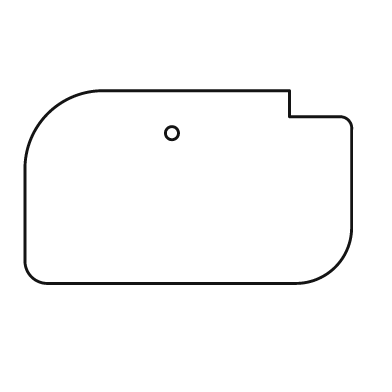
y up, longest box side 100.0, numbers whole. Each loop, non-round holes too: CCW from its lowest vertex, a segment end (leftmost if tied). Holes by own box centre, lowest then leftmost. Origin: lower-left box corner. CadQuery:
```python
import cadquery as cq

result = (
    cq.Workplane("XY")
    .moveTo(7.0, 0.0)
    .lineTo(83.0, 0.0)
    .threePointArc((95.0, 5.0), (100.0, 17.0))
    .lineTo(100.0, 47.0)
    .threePointArc((99.0, 50.0), (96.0, 51.0))
    .lineTo(81.0, 51.0)
    .lineTo(81.0, 59.0)
    .lineTo(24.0, 59.0)
    .threePointArc((7.0, 52.0), (0.0, 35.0))
    .lineTo(0.0, 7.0)
    .threePointArc((2.0, 2.0), (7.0, 0.0))
    .close()
    .moveTo(45.0, 46.0)
    .circle(2.0)
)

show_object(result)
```